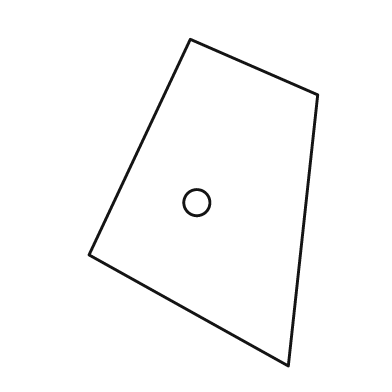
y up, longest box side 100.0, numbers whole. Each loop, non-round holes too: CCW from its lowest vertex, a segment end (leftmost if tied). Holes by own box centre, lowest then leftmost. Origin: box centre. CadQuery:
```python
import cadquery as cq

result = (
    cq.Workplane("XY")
    .moveTo(26.0, -50.0)
    .lineTo(35.0, 33.0)
    .lineTo(-4.0, 50.0)
    .lineTo(-35.0, -16.0)
    .close()
    .moveTo(-2.0, 0.0)
    .circle(4.0)
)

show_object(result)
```